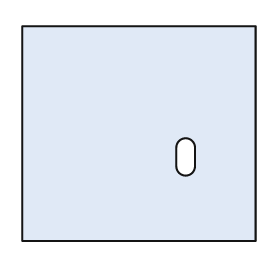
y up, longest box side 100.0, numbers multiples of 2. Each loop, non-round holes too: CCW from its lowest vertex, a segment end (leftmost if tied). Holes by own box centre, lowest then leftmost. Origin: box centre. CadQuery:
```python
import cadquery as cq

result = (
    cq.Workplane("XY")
    .moveTo(-50.0, -46.0)
    .lineTo(50.0, -46.0)
    .lineTo(50.0, 46.0)
    .lineTo(-50.0, 46.0)
    .close()
    .moveTo(16.0, -14.0)
    .threePointArc((20.0, -18.0), (24.0, -14.0))
    .lineTo(24.0, -6.0)
    .threePointArc((20.0, -2.0), (16.0, -6.0))
    .close()
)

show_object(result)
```